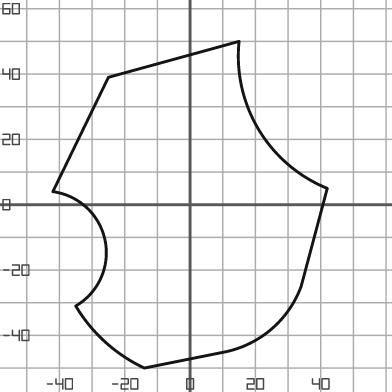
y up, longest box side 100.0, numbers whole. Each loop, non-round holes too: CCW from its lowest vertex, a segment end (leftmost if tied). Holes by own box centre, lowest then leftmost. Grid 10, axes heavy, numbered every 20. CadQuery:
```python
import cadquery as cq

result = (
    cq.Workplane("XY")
    .moveTo(-14.0, -50.0)
    .lineTo(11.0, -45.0)
    .threePointArc((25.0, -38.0), (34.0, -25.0))
    .lineTo(42.0, 5.0)
    .threePointArc((21.0, 23.0), (15.0, 50.0))
    .lineTo(-25.0, 39.0)
    .lineTo(-42.0, 4.0)
    .threePointArc((-26.0, -11.0), (-35.0, -31.0))
    .threePointArc((-26.0, -42.0), (-14.0, -50.0))
    .close()
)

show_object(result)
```